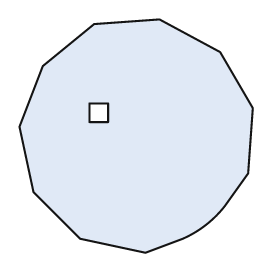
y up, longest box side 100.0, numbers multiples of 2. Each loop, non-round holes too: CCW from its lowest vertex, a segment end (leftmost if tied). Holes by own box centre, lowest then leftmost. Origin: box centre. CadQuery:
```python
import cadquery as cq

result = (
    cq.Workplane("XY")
    .moveTo(4.0, -50.0)
    .lineTo(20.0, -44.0)
    .threePointArc((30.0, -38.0), (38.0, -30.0))
    .lineTo(48.0, -16.0)
    .lineTo(50.0, 12.0)
    .lineTo(36.0, 36.0)
    .lineTo(10.0, 50.0)
    .lineTo(-18.0, 48.0)
    .lineTo(-40.0, 30.0)
    .lineTo(-50.0, 4.0)
    .lineTo(-44.0, -24.0)
    .lineTo(-24.0, -44.0)
    .close()
    .moveTo(-20.0, 6.0)
    .lineTo(-12.0, 6.0)
    .lineTo(-12.0, 14.0)
    .lineTo(-20.0, 14.0)
    .close()
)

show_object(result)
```